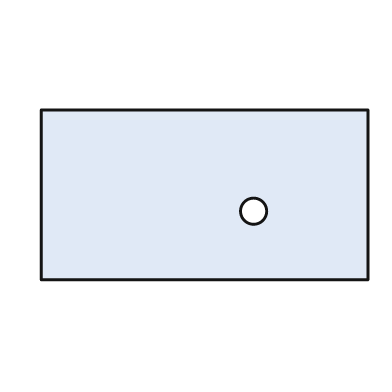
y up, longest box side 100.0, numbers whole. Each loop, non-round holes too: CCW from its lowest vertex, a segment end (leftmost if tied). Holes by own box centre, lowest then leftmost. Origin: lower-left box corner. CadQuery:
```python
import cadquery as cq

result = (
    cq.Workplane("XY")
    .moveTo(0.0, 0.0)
    .lineTo(100.0, 0.0)
    .lineTo(100.0, 52.0)
    .lineTo(0.0, 52.0)
    .close()
    .moveTo(65.0, 21.0)
    .circle(4.0)
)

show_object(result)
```